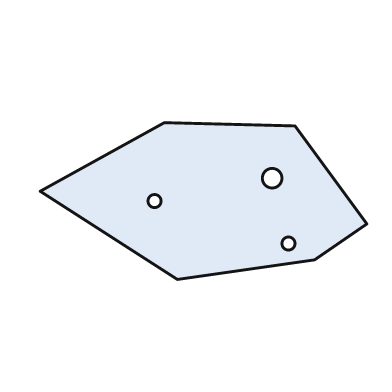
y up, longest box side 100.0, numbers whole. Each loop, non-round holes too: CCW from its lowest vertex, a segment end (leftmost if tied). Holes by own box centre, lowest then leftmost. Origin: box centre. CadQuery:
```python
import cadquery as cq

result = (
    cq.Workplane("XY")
    .moveTo(-8.0, -24.0)
    .lineTo(34.0, -18.0)
    .lineTo(50.0, -7.0)
    .lineTo(28.0, 23.0)
    .lineTo(-12.0, 24.0)
    .lineTo(-50.0, 3.0)
    .close()
    .moveTo(26.0, -13.0)
    .circle(2.0)
    .moveTo(-15.0, 0.0)
    .circle(2.0)
    .moveTo(21.0, 7.0)
    .circle(3.0)
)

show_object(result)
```